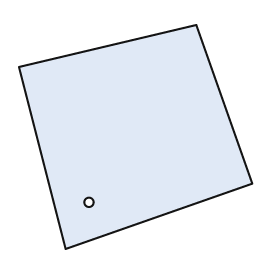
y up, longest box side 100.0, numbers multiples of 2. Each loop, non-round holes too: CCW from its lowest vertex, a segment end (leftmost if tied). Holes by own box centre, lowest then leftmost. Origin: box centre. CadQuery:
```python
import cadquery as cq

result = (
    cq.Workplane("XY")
    .moveTo(-30.0, -48.0)
    .lineTo(50.0, -20.0)
    .lineTo(26.0, 48.0)
    .lineTo(-50.0, 30.0)
    .close()
    .moveTo(-20.0, -28.0)
    .circle(2.0)
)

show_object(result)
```